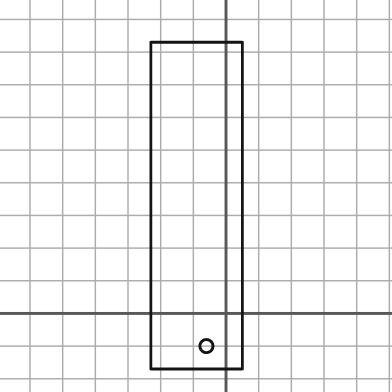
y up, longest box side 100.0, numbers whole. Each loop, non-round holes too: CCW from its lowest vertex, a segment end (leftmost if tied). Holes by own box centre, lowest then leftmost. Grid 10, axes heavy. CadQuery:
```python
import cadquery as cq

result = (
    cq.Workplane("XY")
    .moveTo(-23.0, -17.0)
    .lineTo(5.0, -17.0)
    .lineTo(5.0, 83.0)
    .lineTo(-23.0, 83.0)
    .close()
    .moveTo(-6.0, -10.0)
    .circle(2.0)
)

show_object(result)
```